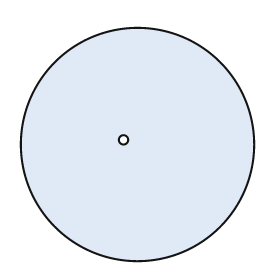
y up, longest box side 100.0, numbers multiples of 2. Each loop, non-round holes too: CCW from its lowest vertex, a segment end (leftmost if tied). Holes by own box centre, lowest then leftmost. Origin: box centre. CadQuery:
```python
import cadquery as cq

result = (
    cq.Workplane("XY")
    .moveTo(0.0, 0.0)
    .circle(50.0)
    .moveTo(-6.0, 2.0)
    .circle(2.0)
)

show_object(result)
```